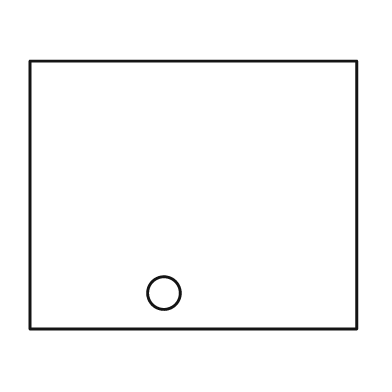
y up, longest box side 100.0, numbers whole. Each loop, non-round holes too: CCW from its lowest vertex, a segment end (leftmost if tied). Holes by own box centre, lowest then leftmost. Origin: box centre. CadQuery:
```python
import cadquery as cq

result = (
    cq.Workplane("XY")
    .moveTo(-50.0, -41.0)
    .lineTo(50.0, -41.0)
    .lineTo(50.0, 41.0)
    .lineTo(-50.0, 41.0)
    .close()
    .moveTo(-9.0, -30.0)
    .circle(5.0)
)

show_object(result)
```